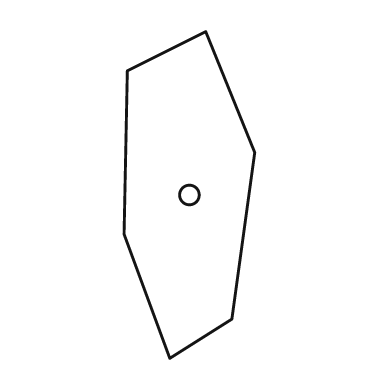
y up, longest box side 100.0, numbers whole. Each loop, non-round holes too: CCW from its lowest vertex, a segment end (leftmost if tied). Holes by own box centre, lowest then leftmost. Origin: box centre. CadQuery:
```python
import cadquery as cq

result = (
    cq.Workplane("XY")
    .moveTo(-6.0, -50.0)
    .lineTo(13.0, -38.0)
    .lineTo(20.0, 13.0)
    .lineTo(5.0, 50.0)
    .lineTo(-19.0, 38.0)
    .lineTo(-20.0, -12.0)
    .close()
    .moveTo(0.0, 0.0)
    .circle(3.0)
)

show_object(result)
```